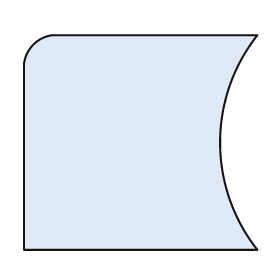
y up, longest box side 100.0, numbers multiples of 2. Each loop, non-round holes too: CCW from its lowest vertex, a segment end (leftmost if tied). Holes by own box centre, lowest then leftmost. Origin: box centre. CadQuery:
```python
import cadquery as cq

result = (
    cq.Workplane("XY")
    .moveTo(-50.0, -46.0)
    .lineTo(50.0, -46.0)
    .threePointArc((34.0, 0.0), (50.0, 46.0))
    .lineTo(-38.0, 46.0)
    .threePointArc((-46.0, 42.0), (-50.0, 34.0))
    .close()
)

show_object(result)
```